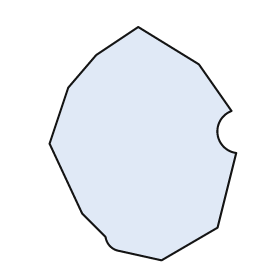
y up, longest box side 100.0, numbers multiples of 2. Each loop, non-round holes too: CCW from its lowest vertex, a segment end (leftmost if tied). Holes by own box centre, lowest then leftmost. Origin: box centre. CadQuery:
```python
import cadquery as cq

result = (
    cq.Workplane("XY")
    .moveTo(8.0, -50.0)
    .lineTo(32.0, -36.0)
    .lineTo(40.0, -4.0)
    .threePointArc((32.0, 4.0), (38.0, 14.0))
    .lineTo(24.0, 34.0)
    .lineTo(-2.0, 50.0)
    .lineTo(-20.0, 38.0)
    .lineTo(-32.0, 24.0)
    .lineTo(-40.0, 0.0)
    .lineTo(-26.0, -30.0)
    .lineTo(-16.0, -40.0)
    .threePointArc((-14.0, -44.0), (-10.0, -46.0))
    .close()
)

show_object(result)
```